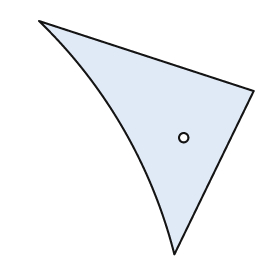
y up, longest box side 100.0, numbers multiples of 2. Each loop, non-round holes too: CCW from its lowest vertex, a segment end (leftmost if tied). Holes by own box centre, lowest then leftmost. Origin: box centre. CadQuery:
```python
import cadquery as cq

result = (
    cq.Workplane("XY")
    .moveTo(12.0, -50.0)
    .lineTo(46.0, 20.0)
    .lineTo(-46.0, 50.0)
    .threePointArc((-10.0, 4.0), (12.0, -50.0))
    .close()
    .moveTo(16.0, 0.0)
    .circle(2.0)
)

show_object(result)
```